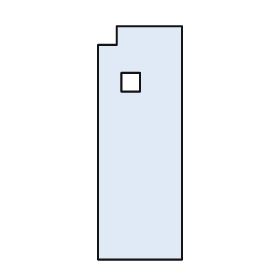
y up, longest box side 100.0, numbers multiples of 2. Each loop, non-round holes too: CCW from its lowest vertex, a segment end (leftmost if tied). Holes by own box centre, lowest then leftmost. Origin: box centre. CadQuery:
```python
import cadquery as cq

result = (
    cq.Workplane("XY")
    .moveTo(-18.0, -50.0)
    .lineTo(18.0, -50.0)
    .lineTo(18.0, 50.0)
    .lineTo(-10.0, 50.0)
    .lineTo(-10.0, 42.0)
    .lineTo(-18.0, 42.0)
    .close()
    .moveTo(-8.0, 22.0)
    .lineTo(0.0, 22.0)
    .lineTo(0.0, 30.0)
    .lineTo(-8.0, 30.0)
    .close()
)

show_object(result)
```